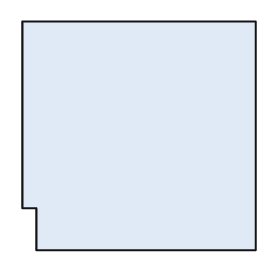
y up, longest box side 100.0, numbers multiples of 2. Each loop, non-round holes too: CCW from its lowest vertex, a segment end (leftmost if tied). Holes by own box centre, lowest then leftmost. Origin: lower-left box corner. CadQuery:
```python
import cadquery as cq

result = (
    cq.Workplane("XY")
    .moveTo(6.0, 0.0)
    .lineTo(100.0, 0.0)
    .lineTo(100.0, 98.0)
    .lineTo(0.0, 98.0)
    .lineTo(0.0, 18.0)
    .lineTo(6.0, 18.0)
    .close()
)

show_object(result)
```